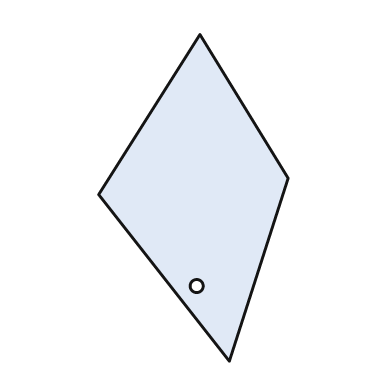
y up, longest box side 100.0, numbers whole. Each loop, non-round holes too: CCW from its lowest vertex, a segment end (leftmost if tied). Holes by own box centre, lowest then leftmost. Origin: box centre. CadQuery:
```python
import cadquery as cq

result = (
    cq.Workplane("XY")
    .moveTo(11.0, -50.0)
    .lineTo(29.0, 6.0)
    .lineTo(2.0, 50.0)
    .lineTo(-29.0, 1.0)
    .close()
    .moveTo(1.0, -27.0)
    .circle(2.0)
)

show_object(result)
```